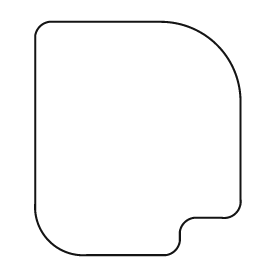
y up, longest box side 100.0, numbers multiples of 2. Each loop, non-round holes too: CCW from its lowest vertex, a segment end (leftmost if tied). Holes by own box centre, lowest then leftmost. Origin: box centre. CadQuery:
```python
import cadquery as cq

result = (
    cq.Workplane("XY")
    .moveTo(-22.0, -50.0)
    .lineTo(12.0, -50.0)
    .threePointArc((16.0, -48.0), (18.0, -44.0))
    .lineTo(18.0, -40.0)
    .threePointArc((20.0, -36.0), (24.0, -34.0))
    .lineTo(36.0, -34.0)
    .threePointArc((42.0, -32.0), (44.0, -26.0))
    .lineTo(44.0, 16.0)
    .threePointArc((34.0, 40.0), (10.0, 50.0))
    .lineTo(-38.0, 50.0)
    .threePointArc((-42.0, 48.0), (-44.0, 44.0))
    .lineTo(-44.0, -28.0)
    .threePointArc((-38.0, -44.0), (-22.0, -50.0))
    .close()
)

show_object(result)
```